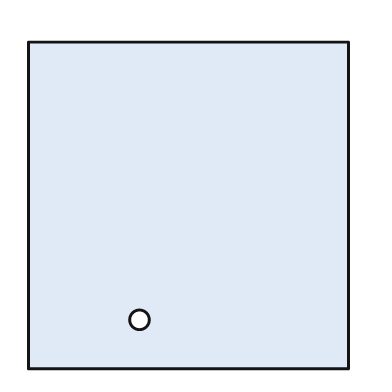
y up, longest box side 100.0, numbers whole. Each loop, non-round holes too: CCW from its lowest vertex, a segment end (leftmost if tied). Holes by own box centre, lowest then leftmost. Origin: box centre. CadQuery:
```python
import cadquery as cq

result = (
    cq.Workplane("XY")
    .moveTo(-49.0, -50.0)
    .lineTo(49.0, -50.0)
    .lineTo(49.0, 50.0)
    .lineTo(-49.0, 50.0)
    .close()
    .moveTo(-15.0, -35.0)
    .circle(3.0)
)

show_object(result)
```